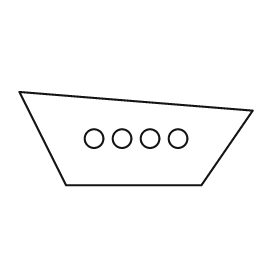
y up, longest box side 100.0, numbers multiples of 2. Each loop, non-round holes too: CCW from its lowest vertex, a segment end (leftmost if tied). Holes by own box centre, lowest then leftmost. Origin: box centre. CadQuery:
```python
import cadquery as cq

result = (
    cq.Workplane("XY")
    .moveTo(-30.0, -20.0)
    .lineTo(28.0, -20.0)
    .lineTo(50.0, 12.0)
    .lineTo(-50.0, 20.0)
    .close()
    .moveTo(-18.0, 0.0)
    .circle(4.0)
    .moveTo(-6.0, 0.0)
    .circle(4.0)
    .moveTo(6.0, 0.0)
    .circle(4.0)
    .moveTo(18.0, 0.0)
    .circle(4.0)
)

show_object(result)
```